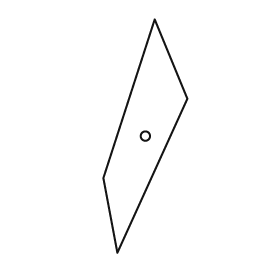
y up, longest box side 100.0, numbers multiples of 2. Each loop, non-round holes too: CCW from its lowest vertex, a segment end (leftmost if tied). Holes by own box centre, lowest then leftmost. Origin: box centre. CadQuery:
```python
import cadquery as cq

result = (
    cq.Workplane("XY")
    .moveTo(-12.0, -50.0)
    .lineTo(18.0, 16.0)
    .lineTo(4.0, 50.0)
    .lineTo(-18.0, -18.0)
    .close()
    .moveTo(0.0, 0.0)
    .circle(2.0)
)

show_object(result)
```